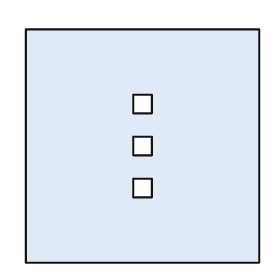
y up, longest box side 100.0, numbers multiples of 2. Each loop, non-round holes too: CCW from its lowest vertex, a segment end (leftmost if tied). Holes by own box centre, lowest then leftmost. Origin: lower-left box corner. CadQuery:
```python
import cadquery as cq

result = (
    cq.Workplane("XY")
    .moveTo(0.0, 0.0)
    .lineTo(100.0, 0.0)
    .lineTo(100.0, 100.0)
    .lineTo(0.0, 100.0)
    .close()
    .moveTo(46.0, 28.0)
    .lineTo(54.0, 28.0)
    .lineTo(54.0, 36.0)
    .lineTo(46.0, 36.0)
    .close()
    .moveTo(46.0, 46.0)
    .lineTo(54.0, 46.0)
    .lineTo(54.0, 54.0)
    .lineTo(46.0, 54.0)
    .close()
    .moveTo(46.0, 64.0)
    .lineTo(54.0, 64.0)
    .lineTo(54.0, 72.0)
    .lineTo(46.0, 72.0)
    .close()
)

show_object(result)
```